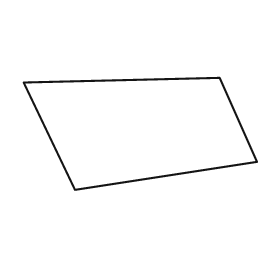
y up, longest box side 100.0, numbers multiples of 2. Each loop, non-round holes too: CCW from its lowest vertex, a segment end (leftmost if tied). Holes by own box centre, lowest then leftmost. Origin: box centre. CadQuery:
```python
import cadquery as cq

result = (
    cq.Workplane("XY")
    .moveTo(-28.0, -24.0)
    .lineTo(50.0, -12.0)
    .lineTo(34.0, 24.0)
    .lineTo(-50.0, 22.0)
    .close()
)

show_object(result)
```